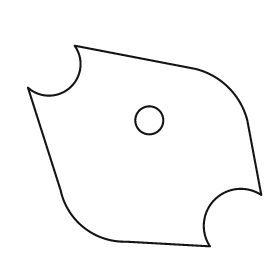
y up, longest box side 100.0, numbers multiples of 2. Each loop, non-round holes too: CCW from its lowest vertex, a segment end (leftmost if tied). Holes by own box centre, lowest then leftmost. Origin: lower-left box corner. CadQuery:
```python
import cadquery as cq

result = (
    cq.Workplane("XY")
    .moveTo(78.0, 0.0)
    .threePointArc((80.0, 20.0), (100.0, 22.0))
    .lineTo(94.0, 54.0)
    .threePointArc((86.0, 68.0), (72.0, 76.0))
    .lineTo(20.0, 86.0)
    .threePointArc((18.0, 68.0), (0.0, 68.0))
    .lineTo(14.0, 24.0)
    .threePointArc((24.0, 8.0), (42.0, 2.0))
    .close()
    .moveTo(52.0, 54.0)
    .circle(6.0)
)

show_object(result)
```